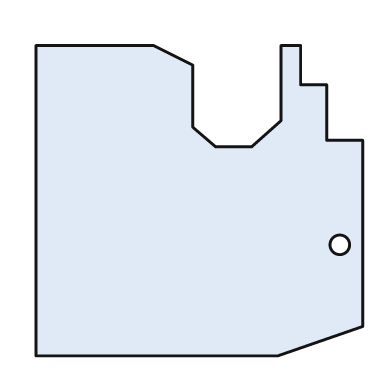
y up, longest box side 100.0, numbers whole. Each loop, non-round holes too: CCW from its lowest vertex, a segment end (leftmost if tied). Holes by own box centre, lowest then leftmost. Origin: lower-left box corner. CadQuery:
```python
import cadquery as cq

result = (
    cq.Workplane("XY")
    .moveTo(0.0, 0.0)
    .lineTo(74.0, 0.0)
    .lineTo(100.0, 9.0)
    .lineTo(100.0, 66.0)
    .lineTo(89.0, 66.0)
    .lineTo(89.0, 83.0)
    .lineTo(81.0, 83.0)
    .lineTo(81.0, 95.0)
    .lineTo(75.0, 95.0)
    .lineTo(75.0, 72.0)
    .lineTo(66.0, 64.0)
    .lineTo(55.0, 64.0)
    .lineTo(48.0, 70.0)
    .lineTo(48.0, 89.0)
    .lineTo(36.0, 95.0)
    .lineTo(0.0, 95.0)
    .close()
    .moveTo(93.0, 34.0)
    .circle(3.0)
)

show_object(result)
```